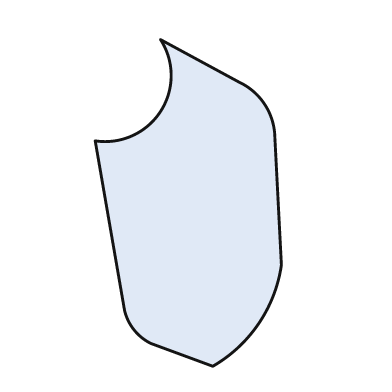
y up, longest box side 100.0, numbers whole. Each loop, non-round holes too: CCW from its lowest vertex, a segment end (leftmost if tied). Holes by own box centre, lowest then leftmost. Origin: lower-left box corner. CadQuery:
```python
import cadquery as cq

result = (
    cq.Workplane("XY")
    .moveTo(36.0, 0.0)
    .threePointArc((50.0, 13.0), (57.0, 31.0))
    .lineTo(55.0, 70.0)
    .threePointArc((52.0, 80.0), (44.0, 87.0))
    .lineTo(20.0, 100.0)
    .threePointArc((20.0, 78.0), (0.0, 69.0))
    .lineTo(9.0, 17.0)
    .threePointArc((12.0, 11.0), (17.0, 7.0))
    .close()
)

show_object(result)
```